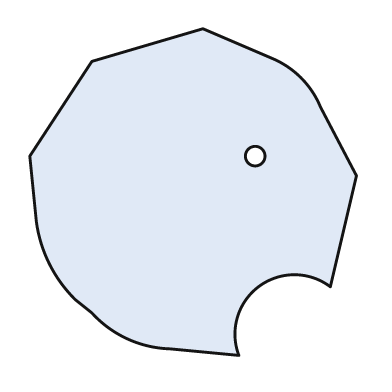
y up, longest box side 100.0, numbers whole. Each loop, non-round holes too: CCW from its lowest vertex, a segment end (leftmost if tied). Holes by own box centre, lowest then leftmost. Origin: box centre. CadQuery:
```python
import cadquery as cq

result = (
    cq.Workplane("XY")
    .moveTo(14.0, -50.0)
    .threePointArc((20.0, -29.0), (42.0, -29.0))
    .lineTo(50.0, 5.0)
    .lineTo(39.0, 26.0)
    .threePointArc((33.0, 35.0), (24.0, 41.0))
    .lineTo(3.0, 50.0)
    .lineTo(-31.0, 40.0)
    .lineTo(-50.0, 11.0)
    .lineTo(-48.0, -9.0)
    .threePointArc((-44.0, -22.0), (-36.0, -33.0))
    .lineTo(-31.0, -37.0)
    .threePointArc((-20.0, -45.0), (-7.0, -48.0))
    .close()
    .moveTo(19.0, 11.0)
    .circle(3.0)
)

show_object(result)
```